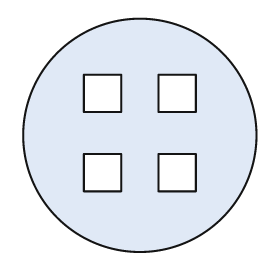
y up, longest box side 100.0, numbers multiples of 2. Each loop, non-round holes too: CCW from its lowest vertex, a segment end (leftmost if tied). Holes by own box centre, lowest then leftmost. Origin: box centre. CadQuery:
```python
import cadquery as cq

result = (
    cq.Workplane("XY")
    .moveTo(0.0, 0.0)
    .circle(50.0)
    .moveTo(-24.0, -24.0)
    .lineTo(-8.0, -24.0)
    .lineTo(-8.0, -8.0)
    .lineTo(-24.0, -8.0)
    .close()
    .moveTo(8.0, -24.0)
    .lineTo(24.0, -24.0)
    .lineTo(24.0, -8.0)
    .lineTo(8.0, -8.0)
    .close()
    .moveTo(-24.0, 10.0)
    .lineTo(-8.0, 10.0)
    .lineTo(-8.0, 26.0)
    .lineTo(-24.0, 26.0)
    .close()
    .moveTo(8.0, 10.0)
    .lineTo(24.0, 10.0)
    .lineTo(24.0, 26.0)
    .lineTo(8.0, 26.0)
    .close()
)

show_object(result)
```